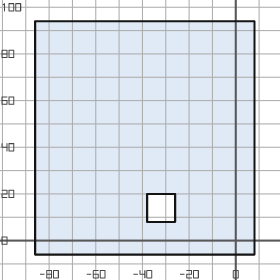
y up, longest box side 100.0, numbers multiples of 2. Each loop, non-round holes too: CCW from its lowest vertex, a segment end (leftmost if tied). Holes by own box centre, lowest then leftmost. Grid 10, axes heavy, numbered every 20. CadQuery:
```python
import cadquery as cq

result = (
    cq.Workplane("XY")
    .moveTo(-86.0, -6.0)
    .lineTo(8.0, -6.0)
    .lineTo(8.0, 94.0)
    .lineTo(-86.0, 94.0)
    .close()
    .moveTo(-38.0, 8.0)
    .lineTo(-26.0, 8.0)
    .lineTo(-26.0, 20.0)
    .lineTo(-38.0, 20.0)
    .close()
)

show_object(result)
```